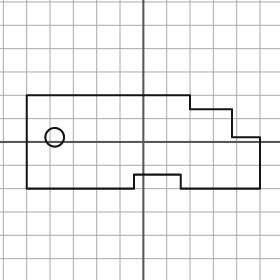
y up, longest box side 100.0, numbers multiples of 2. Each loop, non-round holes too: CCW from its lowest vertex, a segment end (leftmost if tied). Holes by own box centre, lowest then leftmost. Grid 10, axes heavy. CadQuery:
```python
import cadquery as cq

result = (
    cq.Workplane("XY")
    .moveTo(-50.0, -20.0)
    .lineTo(-4.0, -20.0)
    .lineTo(-4.0, -14.0)
    .lineTo(16.0, -14.0)
    .lineTo(16.0, -20.0)
    .lineTo(50.0, -20.0)
    .lineTo(50.0, 2.0)
    .lineTo(38.0, 2.0)
    .lineTo(38.0, 14.0)
    .lineTo(20.0, 14.0)
    .lineTo(20.0, 20.0)
    .lineTo(-50.0, 20.0)
    .close()
    .moveTo(-38.0, 2.0)
    .circle(4.0)
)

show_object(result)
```